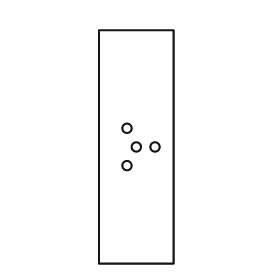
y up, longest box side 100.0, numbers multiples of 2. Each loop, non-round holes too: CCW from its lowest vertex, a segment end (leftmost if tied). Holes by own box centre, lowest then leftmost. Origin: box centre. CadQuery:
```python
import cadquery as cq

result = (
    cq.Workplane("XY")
    .moveTo(-16.0, -50.0)
    .lineTo(16.0, -50.0)
    .lineTo(16.0, 50.0)
    .lineTo(-16.0, 50.0)
    .close()
    .moveTo(-4.0, -8.0)
    .circle(2.0)
    .moveTo(0.0, 0.0)
    .circle(2.0)
    .moveTo(8.0, 0.0)
    .circle(2.0)
    .moveTo(-4.0, 8.0)
    .circle(2.0)
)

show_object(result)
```